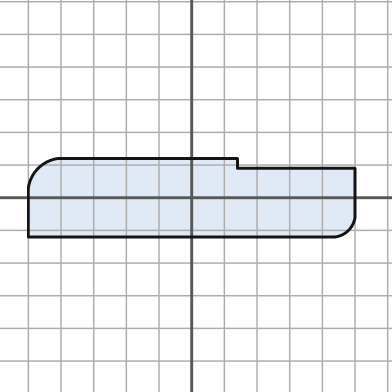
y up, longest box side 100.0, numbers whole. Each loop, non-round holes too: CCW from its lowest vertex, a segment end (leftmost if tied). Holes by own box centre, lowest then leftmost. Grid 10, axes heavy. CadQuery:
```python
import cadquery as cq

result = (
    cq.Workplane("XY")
    .moveTo(-50.0, -12.0)
    .lineTo(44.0, -12.0)
    .threePointArc((48.0, -10.0), (50.0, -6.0))
    .lineTo(50.0, 9.0)
    .lineTo(14.0, 9.0)
    .lineTo(14.0, 12.0)
    .lineTo(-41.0, 12.0)
    .threePointArc((-47.0, 9.0), (-50.0, 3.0))
    .close()
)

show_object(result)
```